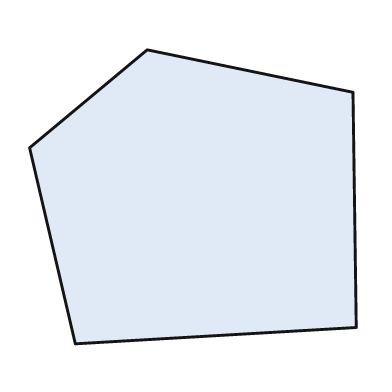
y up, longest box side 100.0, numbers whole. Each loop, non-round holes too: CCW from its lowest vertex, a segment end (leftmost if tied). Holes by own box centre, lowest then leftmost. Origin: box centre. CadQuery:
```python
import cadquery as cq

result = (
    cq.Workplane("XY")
    .moveTo(-36.0, -45.0)
    .lineTo(50.0, -40.0)
    .lineTo(49.0, 32.0)
    .lineTo(-14.0, 45.0)
    .lineTo(-50.0, 15.0)
    .close()
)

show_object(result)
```